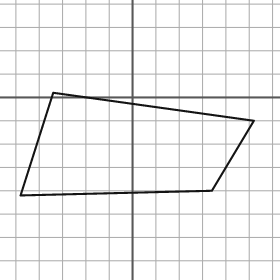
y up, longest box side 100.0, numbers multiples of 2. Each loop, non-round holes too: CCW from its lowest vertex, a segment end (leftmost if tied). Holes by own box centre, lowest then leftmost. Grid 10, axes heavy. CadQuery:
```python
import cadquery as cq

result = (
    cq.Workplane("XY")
    .moveTo(-48.0, -42.0)
    .lineTo(34.0, -40.0)
    .lineTo(52.0, -10.0)
    .lineTo(-34.0, 2.0)
    .close()
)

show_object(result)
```